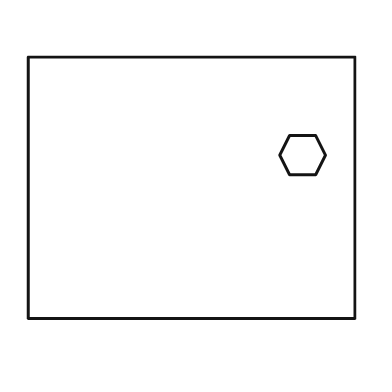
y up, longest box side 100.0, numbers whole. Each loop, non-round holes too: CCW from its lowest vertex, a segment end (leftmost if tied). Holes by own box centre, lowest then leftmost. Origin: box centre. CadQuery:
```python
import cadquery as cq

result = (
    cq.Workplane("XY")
    .moveTo(-50.0, -40.0)
    .lineTo(50.0, -40.0)
    .lineTo(50.0, 40.0)
    .lineTo(-50.0, 40.0)
    .close()
    .moveTo(30.0, 4.0)
    .lineTo(38.0, 4.0)
    .lineTo(41.0, 10.0)
    .lineTo(38.0, 16.0)
    .lineTo(30.0, 16.0)
    .lineTo(27.0, 10.0)
    .close()
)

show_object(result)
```